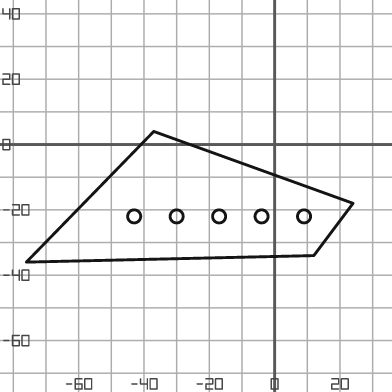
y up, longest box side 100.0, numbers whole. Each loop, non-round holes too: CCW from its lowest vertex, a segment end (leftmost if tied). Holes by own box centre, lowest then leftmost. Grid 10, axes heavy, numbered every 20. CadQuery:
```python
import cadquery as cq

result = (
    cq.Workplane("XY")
    .moveTo(-76.0, -36.0)
    .lineTo(12.0, -34.0)
    .lineTo(24.0, -18.0)
    .lineTo(-37.0, 4.0)
    .close()
    .moveTo(-43.0, -22.0)
    .circle(2.0)
    .moveTo(-30.0, -22.0)
    .circle(2.0)
    .moveTo(-17.0, -22.0)
    .circle(2.0)
    .moveTo(-4.0, -22.0)
    .circle(2.0)
    .moveTo(9.0, -22.0)
    .circle(2.0)
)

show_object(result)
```